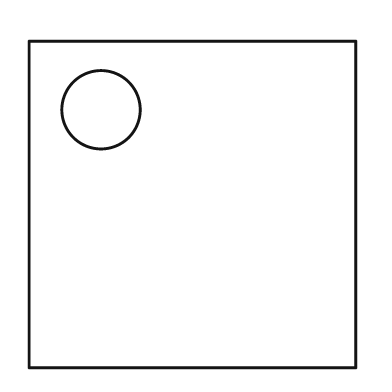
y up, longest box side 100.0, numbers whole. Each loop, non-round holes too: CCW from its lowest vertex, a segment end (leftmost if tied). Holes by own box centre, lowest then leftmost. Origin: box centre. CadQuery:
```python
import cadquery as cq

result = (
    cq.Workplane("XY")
    .moveTo(-50.0, -50.0)
    .lineTo(50.0, -50.0)
    .lineTo(50.0, 50.0)
    .lineTo(-50.0, 50.0)
    .close()
    .moveTo(-28.0, 29.0)
    .circle(12.0)
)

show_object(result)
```